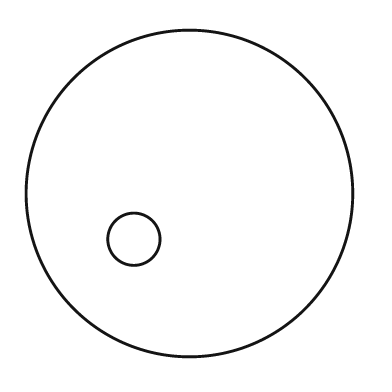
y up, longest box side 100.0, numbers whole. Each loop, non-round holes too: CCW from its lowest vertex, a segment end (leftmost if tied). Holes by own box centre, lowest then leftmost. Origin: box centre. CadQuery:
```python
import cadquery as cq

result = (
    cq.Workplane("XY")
    .moveTo(0.0, 0.0)
    .circle(50.0)
    .moveTo(-17.0, -14.0)
    .circle(8.0)
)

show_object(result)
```